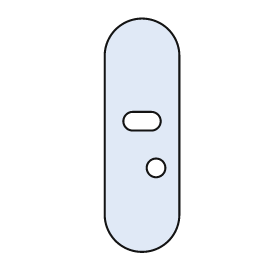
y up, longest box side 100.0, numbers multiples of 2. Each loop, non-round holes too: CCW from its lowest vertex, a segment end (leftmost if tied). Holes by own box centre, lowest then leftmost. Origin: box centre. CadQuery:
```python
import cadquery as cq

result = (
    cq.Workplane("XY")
    .moveTo(-16.0, -34.0)
    .threePointArc((0.0, -50.0), (16.0, -34.0))
    .lineTo(16.0, 34.0)
    .threePointArc((0.0, 50.0), (-16.0, 34.0))
    .close()
    .moveTo(6.0, -14.0)
    .circle(4.0)
    .moveTo(-4.0, 2.0)
    .lineTo(4.0, 2.0)
    .threePointArc((8.0, 6.0), (4.0, 10.0))
    .lineTo(-4.0, 10.0)
    .threePointArc((-8.0, 6.0), (-4.0, 2.0))
    .close()
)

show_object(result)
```